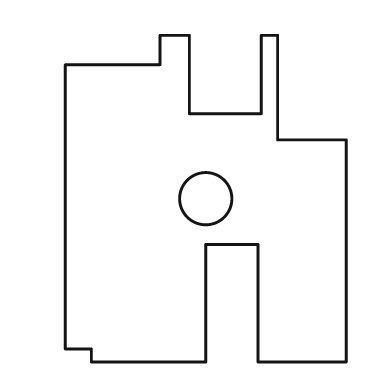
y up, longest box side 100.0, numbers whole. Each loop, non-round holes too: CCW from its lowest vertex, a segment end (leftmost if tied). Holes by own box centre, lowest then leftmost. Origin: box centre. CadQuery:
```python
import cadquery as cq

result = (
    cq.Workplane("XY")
    .moveTo(-35.0, -50.0)
    .lineTo(0.0, -50.0)
    .lineTo(0.0, -14.0)
    .lineTo(16.0, -14.0)
    .lineTo(16.0, -50.0)
    .lineTo(43.0, -50.0)
    .lineTo(43.0, 18.0)
    .lineTo(22.0, 18.0)
    .lineTo(22.0, 50.0)
    .lineTo(17.0, 50.0)
    .lineTo(17.0, 26.0)
    .lineTo(-5.0, 26.0)
    .lineTo(-5.0, 50.0)
    .lineTo(-14.0, 50.0)
    .lineTo(-14.0, 41.0)
    .lineTo(-43.0, 41.0)
    .lineTo(-43.0, -46.0)
    .lineTo(-35.0, -46.0)
    .close()
    .moveTo(0.0, 0.0)
    .circle(8.0)
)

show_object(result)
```